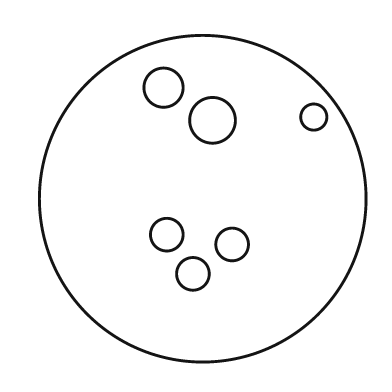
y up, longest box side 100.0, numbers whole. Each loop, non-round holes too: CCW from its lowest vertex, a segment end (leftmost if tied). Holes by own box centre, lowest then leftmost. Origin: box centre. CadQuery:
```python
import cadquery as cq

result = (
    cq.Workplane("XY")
    .moveTo(0.0, 0.0)
    .circle(50.0)
    .moveTo(-3.0, -23.0)
    .circle(5.0)
    .moveTo(9.0, -14.0)
    .circle(5.0)
    .moveTo(-11.0, -11.0)
    .circle(5.0)
    .moveTo(3.0, 24.0)
    .circle(7.0)
    .moveTo(34.0, 25.0)
    .circle(4.0)
    .moveTo(-12.0, 34.0)
    .circle(6.0)
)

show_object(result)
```